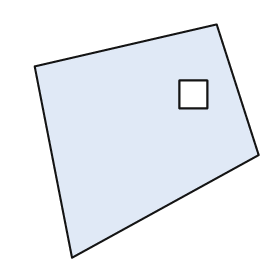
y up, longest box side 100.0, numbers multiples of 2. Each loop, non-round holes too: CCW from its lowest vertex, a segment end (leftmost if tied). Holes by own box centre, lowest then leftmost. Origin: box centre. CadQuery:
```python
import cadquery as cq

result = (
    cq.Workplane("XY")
    .moveTo(-32.0, -50.0)
    .lineTo(48.0, -6.0)
    .lineTo(30.0, 50.0)
    .lineTo(-48.0, 32.0)
    .close()
    .moveTo(14.0, 14.0)
    .lineTo(26.0, 14.0)
    .lineTo(26.0, 26.0)
    .lineTo(14.0, 26.0)
    .close()
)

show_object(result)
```